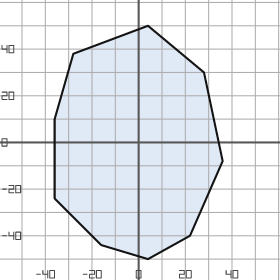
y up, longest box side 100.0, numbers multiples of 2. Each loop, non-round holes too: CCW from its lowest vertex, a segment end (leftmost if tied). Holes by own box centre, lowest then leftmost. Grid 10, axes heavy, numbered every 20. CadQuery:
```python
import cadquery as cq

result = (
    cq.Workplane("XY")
    .moveTo(4.0, -50.0)
    .lineTo(22.0, -40.0)
    .lineTo(36.0, -8.0)
    .lineTo(28.0, 30.0)
    .lineTo(4.0, 50.0)
    .lineTo(-28.0, 38.0)
    .lineTo(-36.0, 10.0)
    .lineTo(-36.0, -24.0)
    .lineTo(-16.0, -44.0)
    .close()
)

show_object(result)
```